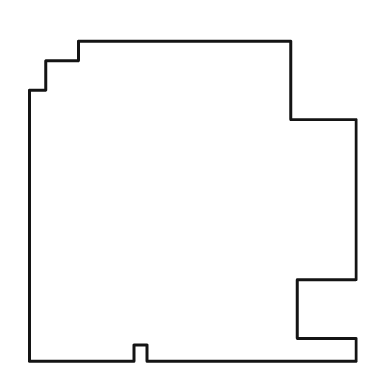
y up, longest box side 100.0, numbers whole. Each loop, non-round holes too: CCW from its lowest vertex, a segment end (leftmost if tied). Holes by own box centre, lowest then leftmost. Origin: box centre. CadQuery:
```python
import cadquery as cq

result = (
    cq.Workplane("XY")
    .moveTo(-50.0, -49.0)
    .lineTo(-18.0, -49.0)
    .lineTo(-18.0, -44.0)
    .lineTo(-14.0, -44.0)
    .lineTo(-14.0, -49.0)
    .lineTo(50.0, -49.0)
    .lineTo(50.0, -42.0)
    .lineTo(32.0, -42.0)
    .lineTo(32.0, -24.0)
    .lineTo(50.0, -24.0)
    .lineTo(50.0, 25.0)
    .lineTo(30.0, 25.0)
    .lineTo(30.0, 49.0)
    .lineTo(-35.0, 49.0)
    .lineTo(-35.0, 43.0)
    .lineTo(-45.0, 43.0)
    .lineTo(-45.0, 34.0)
    .lineTo(-50.0, 34.0)
    .close()
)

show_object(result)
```